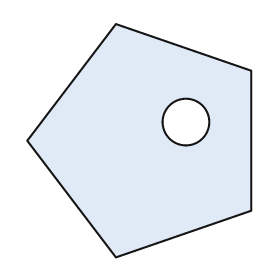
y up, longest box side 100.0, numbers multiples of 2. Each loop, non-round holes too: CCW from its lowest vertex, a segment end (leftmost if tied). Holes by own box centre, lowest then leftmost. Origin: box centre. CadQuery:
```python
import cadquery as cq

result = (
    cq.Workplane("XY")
    .moveTo(-10.0, -50.0)
    .lineTo(48.0, -30.0)
    .lineTo(48.0, 30.0)
    .lineTo(-10.0, 50.0)
    .lineTo(-48.0, 0.0)
    .close()
    .moveTo(20.0, 8.0)
    .circle(10.0)
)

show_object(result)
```